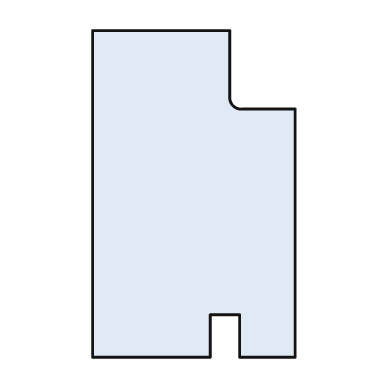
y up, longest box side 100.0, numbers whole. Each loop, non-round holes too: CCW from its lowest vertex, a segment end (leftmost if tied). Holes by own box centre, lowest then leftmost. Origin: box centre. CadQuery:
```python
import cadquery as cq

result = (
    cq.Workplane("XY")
    .moveTo(-31.0, -50.0)
    .lineTo(5.0, -50.0)
    .lineTo(5.0, -37.0)
    .lineTo(14.0, -37.0)
    .lineTo(14.0, -50.0)
    .lineTo(31.0, -50.0)
    .lineTo(31.0, 26.0)
    .lineTo(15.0, 26.0)
    .threePointArc((12.0, 27.0), (11.0, 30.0))
    .lineTo(11.0, 50.0)
    .lineTo(-31.0, 50.0)
    .close()
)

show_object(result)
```